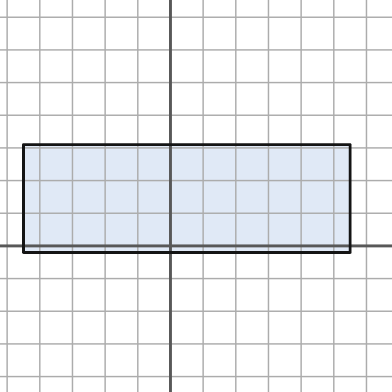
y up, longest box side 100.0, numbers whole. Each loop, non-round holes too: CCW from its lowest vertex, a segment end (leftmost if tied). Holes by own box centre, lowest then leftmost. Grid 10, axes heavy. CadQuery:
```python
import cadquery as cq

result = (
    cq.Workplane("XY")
    .moveTo(-45.0, -2.0)
    .lineTo(55.0, -2.0)
    .lineTo(55.0, 31.0)
    .lineTo(-45.0, 31.0)
    .close()
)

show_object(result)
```